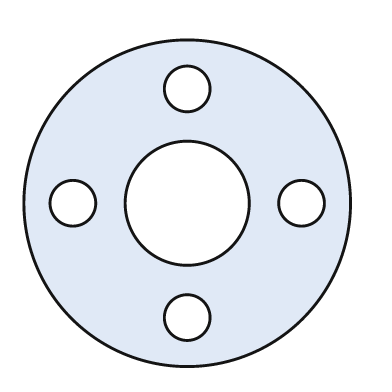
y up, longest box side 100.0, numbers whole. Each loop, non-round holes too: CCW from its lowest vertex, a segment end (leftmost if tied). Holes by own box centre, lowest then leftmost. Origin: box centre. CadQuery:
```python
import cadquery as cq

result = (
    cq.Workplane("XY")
    .moveTo(0.0, 0.0)
    .circle(50.0)
    .moveTo(0.0, -35.0)
    .circle(7.0)
    .moveTo(-35.0, 0.0)
    .circle(7.0)
    .moveTo(0.0, 0.0)
    .circle(19.0)
    .moveTo(35.0, 0.0)
    .circle(7.0)
    .moveTo(0.0, 35.0)
    .circle(7.0)
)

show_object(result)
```